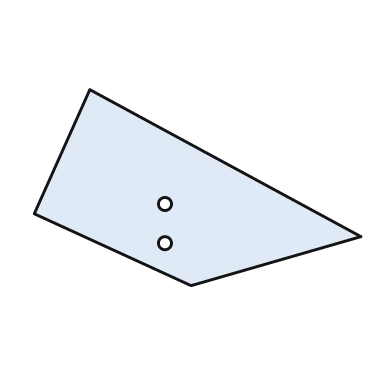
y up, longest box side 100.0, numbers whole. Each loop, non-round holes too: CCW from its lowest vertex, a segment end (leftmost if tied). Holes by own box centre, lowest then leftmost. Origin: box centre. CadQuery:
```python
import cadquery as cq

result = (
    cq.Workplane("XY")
    .moveTo(-2.0, -30.0)
    .lineTo(50.0, -15.0)
    .lineTo(-33.0, 30.0)
    .lineTo(-50.0, -8.0)
    .close()
    .moveTo(-10.0, -17.0)
    .circle(2.0)
    .moveTo(-10.0, -5.0)
    .circle(2.0)
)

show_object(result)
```